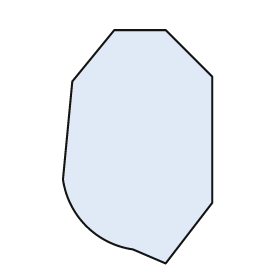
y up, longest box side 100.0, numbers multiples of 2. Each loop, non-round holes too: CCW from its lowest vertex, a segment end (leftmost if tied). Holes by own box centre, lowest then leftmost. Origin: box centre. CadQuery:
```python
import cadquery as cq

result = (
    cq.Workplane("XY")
    .moveTo(12.0, -50.0)
    .lineTo(32.0, -24.0)
    .lineTo(32.0, 30.0)
    .lineTo(12.0, 50.0)
    .lineTo(-10.0, 50.0)
    .lineTo(-28.0, 28.0)
    .lineTo(-32.0, -14.0)
    .threePointArc((-22.0, -34.0), (-2.0, -44.0))
    .close()
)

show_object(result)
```